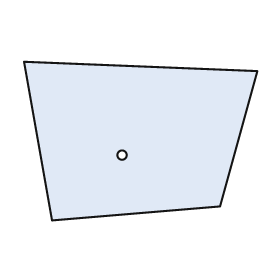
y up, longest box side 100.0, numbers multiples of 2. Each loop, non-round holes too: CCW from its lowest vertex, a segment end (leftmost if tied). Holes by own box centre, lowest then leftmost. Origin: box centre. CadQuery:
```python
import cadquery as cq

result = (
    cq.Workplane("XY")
    .moveTo(-38.0, -34.0)
    .lineTo(34.0, -28.0)
    .lineTo(50.0, 30.0)
    .lineTo(-50.0, 34.0)
    .close()
    .moveTo(-8.0, -6.0)
    .circle(2.0)
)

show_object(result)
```